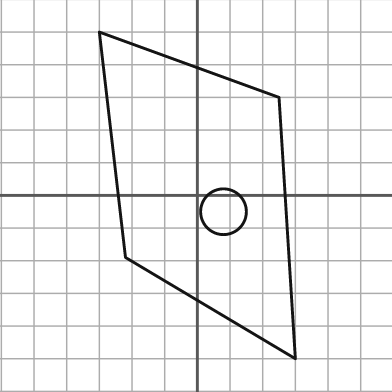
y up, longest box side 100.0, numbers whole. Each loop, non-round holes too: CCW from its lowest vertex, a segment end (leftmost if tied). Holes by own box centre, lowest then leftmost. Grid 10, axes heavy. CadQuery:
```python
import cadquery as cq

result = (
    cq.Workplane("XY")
    .moveTo(30.0, -50.0)
    .lineTo(25.0, 30.0)
    .lineTo(-30.0, 50.0)
    .lineTo(-22.0, -19.0)
    .close()
    .moveTo(8.0, -5.0)
    .circle(7.0)
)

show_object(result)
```